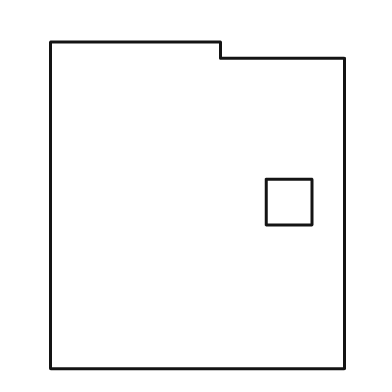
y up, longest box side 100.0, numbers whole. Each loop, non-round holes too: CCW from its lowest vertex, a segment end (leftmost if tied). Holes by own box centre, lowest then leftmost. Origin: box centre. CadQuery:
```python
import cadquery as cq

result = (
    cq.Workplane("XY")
    .moveTo(-45.0, -50.0)
    .lineTo(45.0, -50.0)
    .lineTo(45.0, 45.0)
    .lineTo(7.0, 45.0)
    .lineTo(7.0, 50.0)
    .lineTo(-45.0, 50.0)
    .close()
    .moveTo(21.0, -6.0)
    .lineTo(35.0, -6.0)
    .lineTo(35.0, 8.0)
    .lineTo(21.0, 8.0)
    .close()
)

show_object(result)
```